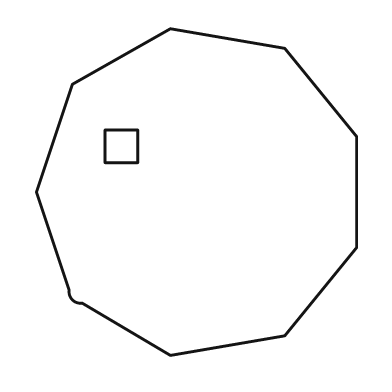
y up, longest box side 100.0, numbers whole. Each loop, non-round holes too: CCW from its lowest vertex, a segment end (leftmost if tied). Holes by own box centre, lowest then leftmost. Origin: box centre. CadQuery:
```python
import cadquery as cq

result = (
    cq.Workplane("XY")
    .moveTo(-8.0, -50.0)
    .lineTo(27.0, -44.0)
    .lineTo(49.0, -17.0)
    .lineTo(49.0, 17.0)
    .lineTo(27.0, 44.0)
    .lineTo(-8.0, 50.0)
    .lineTo(-38.0, 33.0)
    .lineTo(-49.0, 0.0)
    .lineTo(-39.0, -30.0)
    .threePointArc((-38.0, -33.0), (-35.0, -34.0))
    .close()
    .moveTo(-28.0, 9.0)
    .lineTo(-18.0, 9.0)
    .lineTo(-18.0, 19.0)
    .lineTo(-28.0, 19.0)
    .close()
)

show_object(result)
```